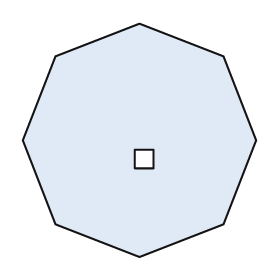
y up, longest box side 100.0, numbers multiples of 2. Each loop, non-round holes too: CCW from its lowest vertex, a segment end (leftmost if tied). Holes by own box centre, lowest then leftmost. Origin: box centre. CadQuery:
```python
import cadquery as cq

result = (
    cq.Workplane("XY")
    .moveTo(0.0, -50.0)
    .lineTo(36.0, -36.0)
    .lineTo(50.0, 0.0)
    .lineTo(36.0, 36.0)
    .lineTo(0.0, 50.0)
    .lineTo(-36.0, 36.0)
    .lineTo(-50.0, 0.0)
    .lineTo(-36.0, -36.0)
    .close()
    .moveTo(-2.0, -12.0)
    .lineTo(6.0, -12.0)
    .lineTo(6.0, -4.0)
    .lineTo(-2.0, -4.0)
    .close()
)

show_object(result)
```